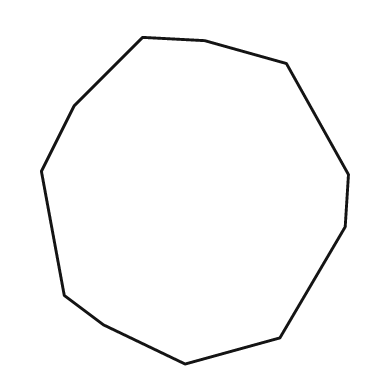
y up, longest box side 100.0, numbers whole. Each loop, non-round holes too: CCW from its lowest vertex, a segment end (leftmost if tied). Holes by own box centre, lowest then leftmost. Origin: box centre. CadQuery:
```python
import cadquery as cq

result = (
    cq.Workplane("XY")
    .moveTo(-3.0, -50.0)
    .lineTo(26.0, -42.0)
    .lineTo(46.0, -8.0)
    .lineTo(47.0, 8.0)
    .lineTo(28.0, 42.0)
    .lineTo(3.0, 49.0)
    .lineTo(-16.0, 50.0)
    .lineTo(-37.0, 29.0)
    .lineTo(-47.0, 9.0)
    .lineTo(-40.0, -29.0)
    .lineTo(-28.0, -38.0)
    .close()
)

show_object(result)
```